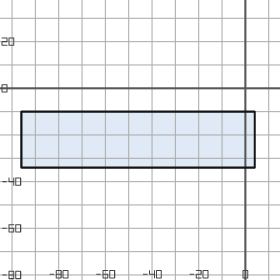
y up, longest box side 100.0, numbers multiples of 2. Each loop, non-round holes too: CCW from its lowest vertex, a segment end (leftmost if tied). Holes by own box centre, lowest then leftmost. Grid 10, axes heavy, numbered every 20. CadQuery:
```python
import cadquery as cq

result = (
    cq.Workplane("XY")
    .moveTo(-96.0, -34.0)
    .lineTo(4.0, -34.0)
    .lineTo(4.0, -10.0)
    .lineTo(-96.0, -10.0)
    .close()
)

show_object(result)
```